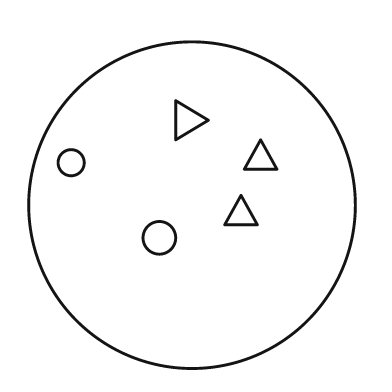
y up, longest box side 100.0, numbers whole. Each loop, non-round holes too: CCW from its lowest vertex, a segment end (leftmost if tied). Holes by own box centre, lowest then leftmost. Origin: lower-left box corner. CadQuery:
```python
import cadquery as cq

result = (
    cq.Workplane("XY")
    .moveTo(50.0, 50.0)
    .circle(50.0)
    .moveTo(40.0, 40.0)
    .circle(5.0)
    .moveTo(60.0, 44.0)
    .lineTo(70.0, 44.0)
    .lineTo(65.0, 53.0)
    .close()
    .moveTo(13.0, 63.0)
    .circle(4.0)
    .moveTo(66.0, 61.0)
    .lineTo(76.0, 61.0)
    .lineTo(71.0, 70.0)
    .close()
    .moveTo(45.0, 70.0)
    .lineTo(55.0, 76.0)
    .lineTo(45.0, 82.0)
    .close()
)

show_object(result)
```